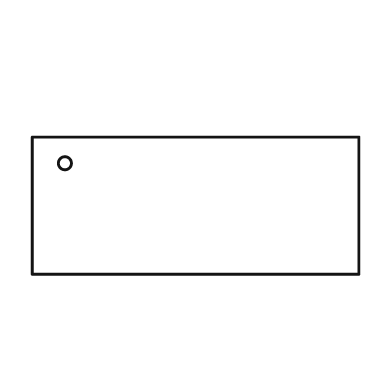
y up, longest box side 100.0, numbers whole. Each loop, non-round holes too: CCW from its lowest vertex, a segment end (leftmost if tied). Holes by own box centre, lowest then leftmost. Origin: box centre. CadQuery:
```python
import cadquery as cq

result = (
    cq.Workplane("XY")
    .moveTo(-50.0, -21.0)
    .lineTo(50.0, -21.0)
    .lineTo(50.0, 21.0)
    .lineTo(-50.0, 21.0)
    .close()
    .moveTo(-40.0, 13.0)
    .circle(2.0)
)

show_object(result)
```